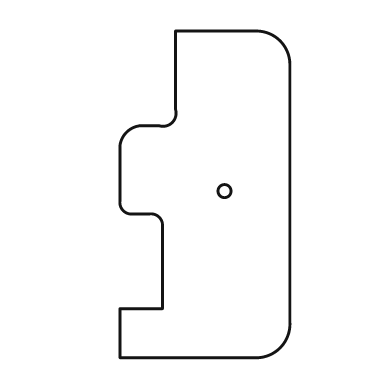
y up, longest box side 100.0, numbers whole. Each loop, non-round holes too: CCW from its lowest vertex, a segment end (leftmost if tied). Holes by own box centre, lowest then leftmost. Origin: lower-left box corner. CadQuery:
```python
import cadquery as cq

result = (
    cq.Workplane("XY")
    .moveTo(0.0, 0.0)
    .lineTo(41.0, 0.0)
    .threePointArc((49.0, 3.0), (52.0, 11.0))
    .lineTo(52.0, 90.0)
    .threePointArc((49.0, 97.0), (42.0, 100.0))
    .lineTo(17.0, 100.0)
    .lineTo(17.0, 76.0)
    .threePointArc((16.0, 72.0), (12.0, 71.0))
    .lineTo(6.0, 71.0)
    .threePointArc((2.0, 69.0), (0.0, 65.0))
    .lineTo(0.0, 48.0)
    .threePointArc((1.0, 45.0), (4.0, 44.0))
    .lineTo(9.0, 44.0)
    .threePointArc((12.0, 43.0), (13.0, 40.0))
    .lineTo(13.0, 15.0)
    .lineTo(0.0, 15.0)
    .close()
    .moveTo(32.0, 51.0)
    .circle(2.0)
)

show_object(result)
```